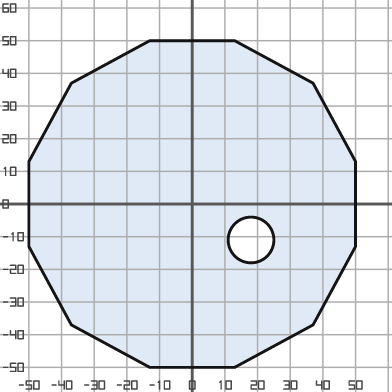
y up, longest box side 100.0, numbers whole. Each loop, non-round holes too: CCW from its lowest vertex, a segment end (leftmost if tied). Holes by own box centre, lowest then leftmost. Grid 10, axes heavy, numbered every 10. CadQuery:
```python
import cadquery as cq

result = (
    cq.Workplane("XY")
    .moveTo(-13.0, -50.0)
    .lineTo(13.0, -50.0)
    .lineTo(37.0, -37.0)
    .lineTo(50.0, -13.0)
    .lineTo(50.0, 13.0)
    .lineTo(37.0, 37.0)
    .lineTo(13.0, 50.0)
    .lineTo(-13.0, 50.0)
    .lineTo(-37.0, 37.0)
    .lineTo(-50.0, 13.0)
    .lineTo(-50.0, -13.0)
    .lineTo(-37.0, -37.0)
    .close()
    .moveTo(18.0, -11.0)
    .circle(7.0)
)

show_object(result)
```